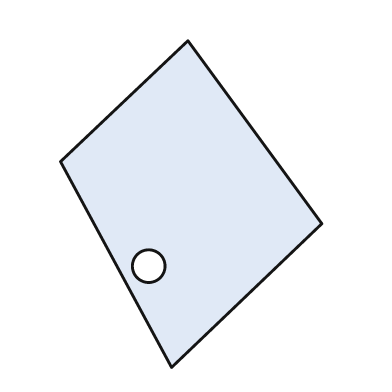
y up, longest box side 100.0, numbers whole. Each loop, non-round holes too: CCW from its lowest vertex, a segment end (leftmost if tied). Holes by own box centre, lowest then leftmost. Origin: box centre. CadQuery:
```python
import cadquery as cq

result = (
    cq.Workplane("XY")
    .moveTo(-6.0, -50.0)
    .lineTo(40.0, -6.0)
    .lineTo(-1.0, 50.0)
    .lineTo(-40.0, 13.0)
    .close()
    .moveTo(-13.0, -19.0)
    .circle(5.0)
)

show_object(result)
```